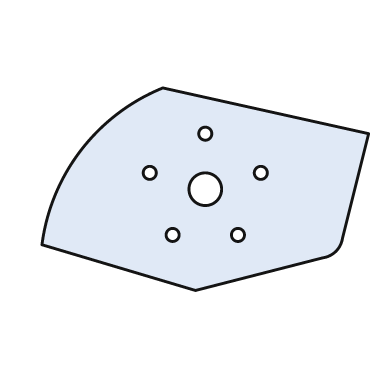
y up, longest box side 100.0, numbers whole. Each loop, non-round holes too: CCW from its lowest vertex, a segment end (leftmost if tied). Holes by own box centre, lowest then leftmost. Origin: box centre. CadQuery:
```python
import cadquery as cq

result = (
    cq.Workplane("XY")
    .moveTo(-3.0, -31.0)
    .lineTo(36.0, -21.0)
    .threePointArc((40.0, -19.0), (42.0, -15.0))
    .lineTo(50.0, 17.0)
    .lineTo(-13.0, 31.0)
    .threePointArc((-38.0, 12.0), (-50.0, -17.0))
    .close()
    .moveTo(-10.0, -14.0)
    .circle(2.0)
    .moveTo(10.0, -14.0)
    .circle(2.0)
    .moveTo(0.0, 0.0)
    .circle(5.0)
    .moveTo(-17.0, 5.0)
    .circle(2.0)
    .moveTo(17.0, 5.0)
    .circle(2.0)
    .moveTo(0.0, 17.0)
    .circle(2.0)
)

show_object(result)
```